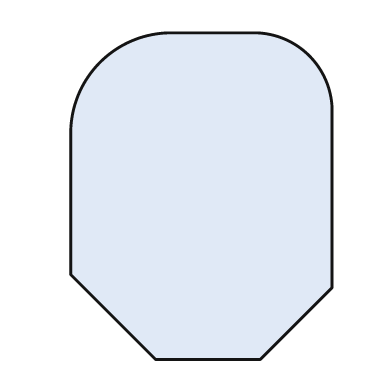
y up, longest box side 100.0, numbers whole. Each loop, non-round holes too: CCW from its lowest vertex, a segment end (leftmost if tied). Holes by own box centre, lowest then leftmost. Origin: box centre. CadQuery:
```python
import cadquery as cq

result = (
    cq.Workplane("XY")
    .moveTo(-14.0, -50.0)
    .lineTo(18.0, -50.0)
    .lineTo(40.0, -28.0)
    .lineTo(40.0, 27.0)
    .threePointArc((33.0, 43.0), (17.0, 50.0))
    .lineTo(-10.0, 50.0)
    .threePointArc((-31.0, 41.0), (-40.0, 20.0))
    .lineTo(-40.0, -24.0)
    .close()
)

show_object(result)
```